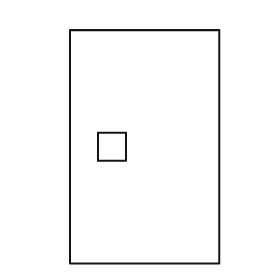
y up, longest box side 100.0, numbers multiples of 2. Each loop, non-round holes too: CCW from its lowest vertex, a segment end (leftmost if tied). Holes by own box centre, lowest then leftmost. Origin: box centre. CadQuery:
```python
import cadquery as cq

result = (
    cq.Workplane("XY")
    .moveTo(-32.0, -50.0)
    .lineTo(32.0, -50.0)
    .lineTo(32.0, 50.0)
    .lineTo(-32.0, 50.0)
    .close()
    .moveTo(-20.0, -6.0)
    .lineTo(-8.0, -6.0)
    .lineTo(-8.0, 6.0)
    .lineTo(-20.0, 6.0)
    .close()
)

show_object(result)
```